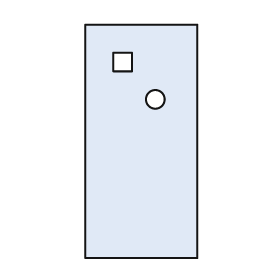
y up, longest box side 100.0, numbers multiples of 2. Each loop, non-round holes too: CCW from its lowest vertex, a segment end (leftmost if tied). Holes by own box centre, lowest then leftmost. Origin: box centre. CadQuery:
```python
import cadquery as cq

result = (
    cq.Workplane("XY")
    .moveTo(-24.0, -50.0)
    .lineTo(24.0, -50.0)
    .lineTo(24.0, 50.0)
    .lineTo(-24.0, 50.0)
    .close()
    .moveTo(6.0, 18.0)
    .circle(4.0)
    .moveTo(-12.0, 30.0)
    .lineTo(-4.0, 30.0)
    .lineTo(-4.0, 38.0)
    .lineTo(-12.0, 38.0)
    .close()
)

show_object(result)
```